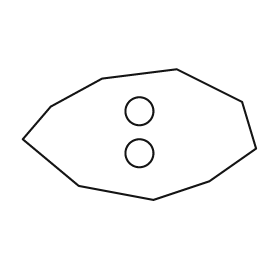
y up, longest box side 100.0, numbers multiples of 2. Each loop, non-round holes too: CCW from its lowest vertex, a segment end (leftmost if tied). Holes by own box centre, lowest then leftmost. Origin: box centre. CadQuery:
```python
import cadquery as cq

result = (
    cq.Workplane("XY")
    .moveTo(6.0, -28.0)
    .lineTo(30.0, -20.0)
    .lineTo(50.0, -6.0)
    .lineTo(44.0, 14.0)
    .lineTo(16.0, 28.0)
    .lineTo(-16.0, 24.0)
    .lineTo(-38.0, 12.0)
    .lineTo(-50.0, -2.0)
    .lineTo(-26.0, -22.0)
    .close()
    .moveTo(0.0, -8.0)
    .circle(6.0)
    .moveTo(0.0, 10.0)
    .circle(6.0)
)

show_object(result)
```